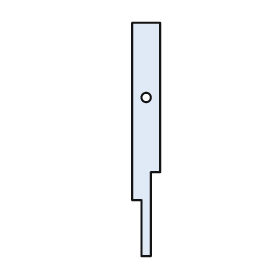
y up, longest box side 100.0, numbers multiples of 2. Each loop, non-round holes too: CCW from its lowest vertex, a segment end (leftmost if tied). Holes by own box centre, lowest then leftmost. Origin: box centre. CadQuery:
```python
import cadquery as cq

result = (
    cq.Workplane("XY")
    .moveTo(-2.0, -50.0)
    .lineTo(2.0, -50.0)
    .lineTo(2.0, -14.0)
    .lineTo(6.0, -14.0)
    .lineTo(6.0, 50.0)
    .lineTo(-6.0, 50.0)
    .lineTo(-6.0, -26.0)
    .lineTo(-2.0, -26.0)
    .close()
    .moveTo(0.0, 18.0)
    .circle(2.0)
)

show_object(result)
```